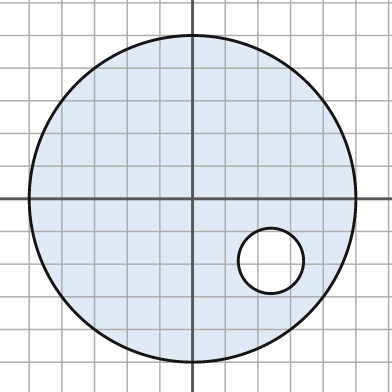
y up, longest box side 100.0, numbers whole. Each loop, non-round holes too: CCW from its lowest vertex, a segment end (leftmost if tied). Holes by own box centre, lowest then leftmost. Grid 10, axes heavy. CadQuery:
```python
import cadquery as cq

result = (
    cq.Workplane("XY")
    .moveTo(0.0, 0.0)
    .circle(50.0)
    .moveTo(24.0, -19.0)
    .circle(10.0)
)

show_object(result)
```